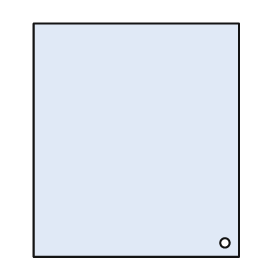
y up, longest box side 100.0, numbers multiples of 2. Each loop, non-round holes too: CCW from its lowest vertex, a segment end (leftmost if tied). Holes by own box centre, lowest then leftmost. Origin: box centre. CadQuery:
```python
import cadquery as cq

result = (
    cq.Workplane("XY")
    .moveTo(-44.0, -50.0)
    .lineTo(44.0, -50.0)
    .lineTo(44.0, 50.0)
    .lineTo(-44.0, 50.0)
    .close()
    .moveTo(38.0, -44.0)
    .circle(2.0)
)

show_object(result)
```